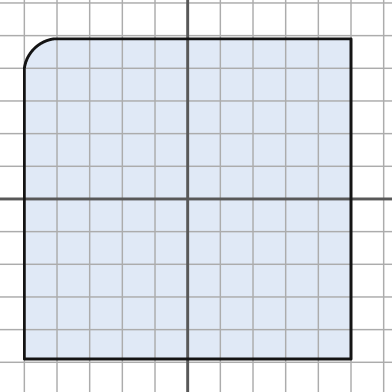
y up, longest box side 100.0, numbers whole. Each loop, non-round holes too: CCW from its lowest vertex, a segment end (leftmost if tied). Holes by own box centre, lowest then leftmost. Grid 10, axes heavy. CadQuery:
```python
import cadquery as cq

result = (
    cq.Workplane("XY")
    .moveTo(-50.0, -49.0)
    .lineTo(50.0, -49.0)
    .lineTo(50.0, 49.0)
    .lineTo(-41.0, 49.0)
    .threePointArc((-47.0, 46.0), (-50.0, 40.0))
    .close()
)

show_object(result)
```